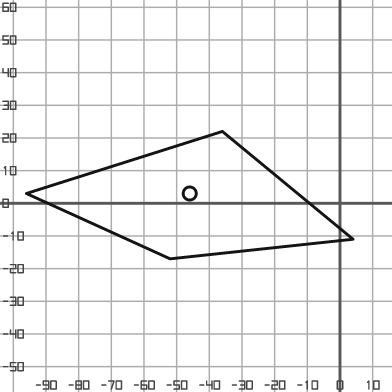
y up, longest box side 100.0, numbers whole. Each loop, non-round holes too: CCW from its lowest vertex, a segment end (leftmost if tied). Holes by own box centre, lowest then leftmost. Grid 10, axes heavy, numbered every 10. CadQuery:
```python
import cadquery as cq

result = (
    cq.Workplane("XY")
    .moveTo(-52.0, -17.0)
    .lineTo(4.0, -11.0)
    .lineTo(-36.0, 22.0)
    .lineTo(-96.0, 3.0)
    .close()
    .moveTo(-46.0, 3.0)
    .circle(2.0)
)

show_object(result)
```